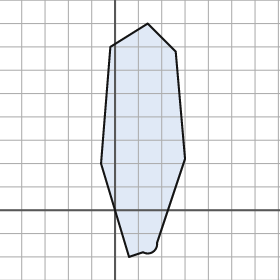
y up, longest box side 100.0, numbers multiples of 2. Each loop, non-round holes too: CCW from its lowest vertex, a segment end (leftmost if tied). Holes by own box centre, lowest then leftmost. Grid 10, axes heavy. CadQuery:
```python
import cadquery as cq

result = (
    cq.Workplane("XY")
    .moveTo(6.0, -20.0)
    .lineTo(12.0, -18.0)
    .threePointArc((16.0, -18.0), (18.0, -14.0))
    .lineTo(30.0, 22.0)
    .lineTo(26.0, 68.0)
    .lineTo(14.0, 80.0)
    .lineTo(-2.0, 70.0)
    .lineTo(-6.0, 20.0)
    .close()
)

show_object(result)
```